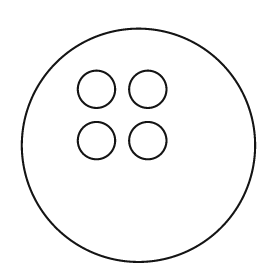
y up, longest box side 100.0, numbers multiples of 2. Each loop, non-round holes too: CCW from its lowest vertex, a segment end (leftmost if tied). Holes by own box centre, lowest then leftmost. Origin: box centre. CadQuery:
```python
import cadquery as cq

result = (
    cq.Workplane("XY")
    .moveTo(0.0, 0.0)
    .circle(50.0)
    .moveTo(-18.0, 2.0)
    .circle(8.0)
    .moveTo(4.0, 2.0)
    .circle(8.0)
    .moveTo(-18.0, 24.0)
    .circle(8.0)
    .moveTo(4.0, 24.0)
    .circle(8.0)
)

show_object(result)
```